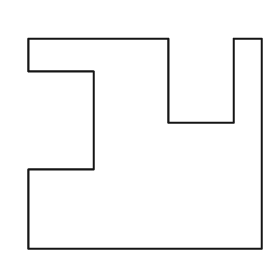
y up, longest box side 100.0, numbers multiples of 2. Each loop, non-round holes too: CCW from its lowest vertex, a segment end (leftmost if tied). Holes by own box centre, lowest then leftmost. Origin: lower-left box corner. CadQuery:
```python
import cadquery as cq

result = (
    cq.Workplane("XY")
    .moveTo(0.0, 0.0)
    .lineTo(100.0, 0.0)
    .lineTo(100.0, 90.0)
    .lineTo(88.0, 90.0)
    .lineTo(88.0, 54.0)
    .lineTo(60.0, 54.0)
    .lineTo(60.0, 90.0)
    .lineTo(0.0, 90.0)
    .lineTo(0.0, 76.0)
    .lineTo(28.0, 76.0)
    .lineTo(28.0, 34.0)
    .lineTo(0.0, 34.0)
    .close()
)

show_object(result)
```